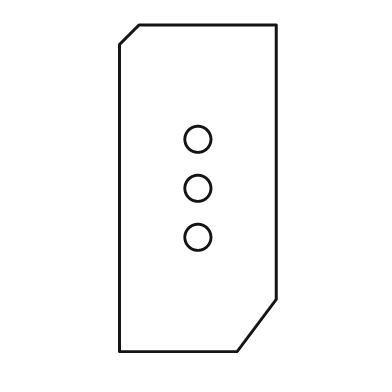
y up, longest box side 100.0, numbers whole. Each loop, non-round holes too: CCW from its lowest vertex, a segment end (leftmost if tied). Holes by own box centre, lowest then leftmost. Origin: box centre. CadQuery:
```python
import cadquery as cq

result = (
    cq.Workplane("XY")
    .moveTo(-24.0, -50.0)
    .lineTo(12.0, -50.0)
    .lineTo(24.0, -34.0)
    .lineTo(24.0, 50.0)
    .lineTo(-18.0, 50.0)
    .lineTo(-24.0, 44.0)
    .close()
    .moveTo(0.0, -15.0)
    .circle(4.0)
    .moveTo(0.0, 0.0)
    .circle(4.0)
    .moveTo(0.0, 15.0)
    .circle(4.0)
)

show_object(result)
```